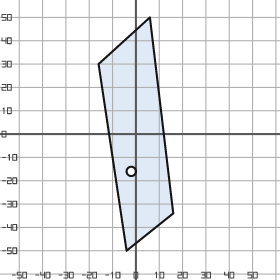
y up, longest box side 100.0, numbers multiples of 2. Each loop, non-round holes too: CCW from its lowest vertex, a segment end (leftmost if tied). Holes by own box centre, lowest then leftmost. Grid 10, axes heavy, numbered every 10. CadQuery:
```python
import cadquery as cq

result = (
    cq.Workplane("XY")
    .moveTo(-4.0, -50.0)
    .lineTo(16.0, -34.0)
    .lineTo(6.0, 50.0)
    .lineTo(-16.0, 30.0)
    .close()
    .moveTo(-2.0, -16.0)
    .circle(2.0)
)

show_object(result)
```